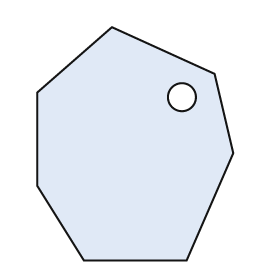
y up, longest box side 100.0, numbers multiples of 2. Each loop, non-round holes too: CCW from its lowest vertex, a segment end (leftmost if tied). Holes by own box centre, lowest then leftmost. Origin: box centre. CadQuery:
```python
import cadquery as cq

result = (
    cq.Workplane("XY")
    .moveTo(-22.0, -50.0)
    .lineTo(22.0, -50.0)
    .lineTo(42.0, -4.0)
    .lineTo(34.0, 30.0)
    .lineTo(-10.0, 50.0)
    .lineTo(-42.0, 22.0)
    .lineTo(-42.0, -18.0)
    .close()
    .moveTo(20.0, 20.0)
    .circle(6.0)
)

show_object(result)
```